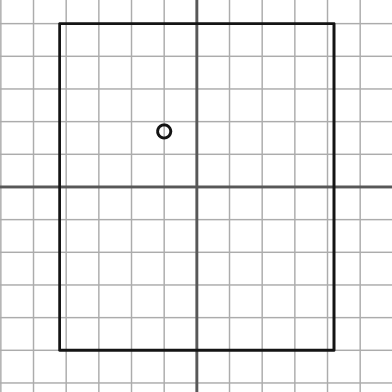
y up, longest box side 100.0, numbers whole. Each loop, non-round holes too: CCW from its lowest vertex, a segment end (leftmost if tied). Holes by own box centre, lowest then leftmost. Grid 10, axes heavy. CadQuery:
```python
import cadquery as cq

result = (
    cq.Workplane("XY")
    .moveTo(-42.0, -50.0)
    .lineTo(42.0, -50.0)
    .lineTo(42.0, 50.0)
    .lineTo(-42.0, 50.0)
    .close()
    .moveTo(-10.0, 17.0)
    .circle(2.0)
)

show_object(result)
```